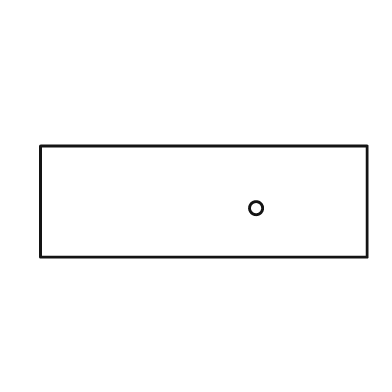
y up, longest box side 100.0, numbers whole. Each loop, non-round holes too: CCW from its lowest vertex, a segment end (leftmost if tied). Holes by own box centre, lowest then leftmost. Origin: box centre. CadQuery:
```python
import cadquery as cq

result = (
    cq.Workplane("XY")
    .moveTo(-50.0, -17.0)
    .lineTo(50.0, -17.0)
    .lineTo(50.0, 17.0)
    .lineTo(-50.0, 17.0)
    .close()
    .moveTo(16.0, -2.0)
    .circle(2.0)
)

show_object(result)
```